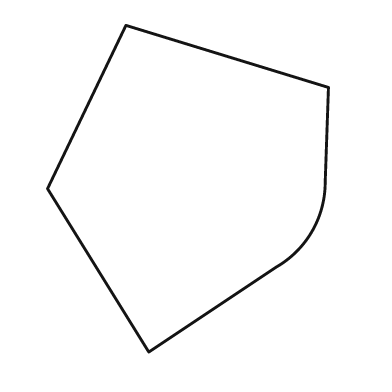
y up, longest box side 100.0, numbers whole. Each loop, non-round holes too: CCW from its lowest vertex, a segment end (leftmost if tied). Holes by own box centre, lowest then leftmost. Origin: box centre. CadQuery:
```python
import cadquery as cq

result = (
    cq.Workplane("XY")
    .moveTo(-12.0, -50.0)
    .lineTo(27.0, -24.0)
    .threePointArc((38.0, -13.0), (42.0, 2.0))
    .lineTo(43.0, 31.0)
    .lineTo(-19.0, 50.0)
    .lineTo(-43.0, 0.0)
    .close()
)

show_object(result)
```